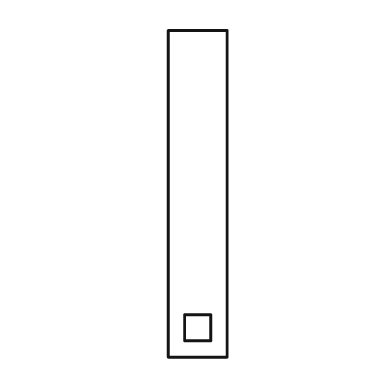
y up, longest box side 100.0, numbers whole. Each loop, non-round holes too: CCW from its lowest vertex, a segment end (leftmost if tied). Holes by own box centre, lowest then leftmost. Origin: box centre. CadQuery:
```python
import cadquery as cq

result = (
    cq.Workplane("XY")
    .moveTo(-9.0, -50.0)
    .lineTo(9.0, -50.0)
    .lineTo(9.0, 50.0)
    .lineTo(-9.0, 50.0)
    .close()
    .moveTo(-4.0, -45.0)
    .lineTo(4.0, -45.0)
    .lineTo(4.0, -37.0)
    .lineTo(-4.0, -37.0)
    .close()
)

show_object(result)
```